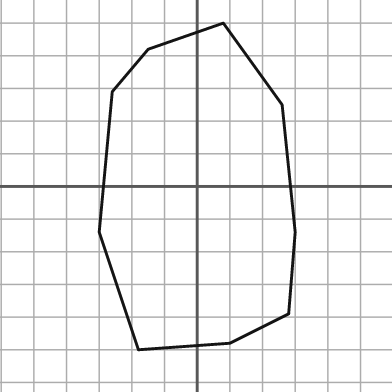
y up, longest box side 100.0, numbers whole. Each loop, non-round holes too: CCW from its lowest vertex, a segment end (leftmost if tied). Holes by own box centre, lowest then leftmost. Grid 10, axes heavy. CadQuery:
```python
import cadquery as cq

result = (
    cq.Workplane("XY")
    .moveTo(-18.0, -50.0)
    .lineTo(10.0, -48.0)
    .lineTo(28.0, -39.0)
    .lineTo(30.0, -14.0)
    .lineTo(26.0, 25.0)
    .lineTo(8.0, 50.0)
    .lineTo(-15.0, 42.0)
    .lineTo(-26.0, 29.0)
    .lineTo(-30.0, -14.0)
    .close()
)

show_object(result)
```